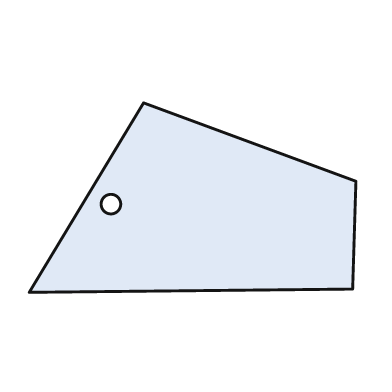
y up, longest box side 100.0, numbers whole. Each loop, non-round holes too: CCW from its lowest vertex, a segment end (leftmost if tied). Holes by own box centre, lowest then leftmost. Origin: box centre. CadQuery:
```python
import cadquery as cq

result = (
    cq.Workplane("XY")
    .moveTo(-50.0, -29.0)
    .lineTo(49.0, -28.0)
    .lineTo(50.0, 5.0)
    .lineTo(-15.0, 29.0)
    .close()
    .moveTo(-25.0, -2.0)
    .circle(3.0)
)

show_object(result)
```